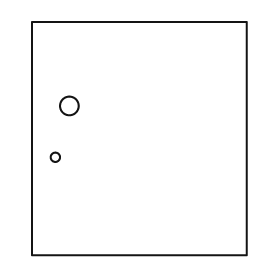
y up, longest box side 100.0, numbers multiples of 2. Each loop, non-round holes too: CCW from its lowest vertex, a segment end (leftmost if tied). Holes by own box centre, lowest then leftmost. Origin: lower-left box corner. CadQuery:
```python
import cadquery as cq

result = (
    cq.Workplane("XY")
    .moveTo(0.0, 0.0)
    .lineTo(92.0, 0.0)
    .lineTo(92.0, 100.0)
    .lineTo(0.0, 100.0)
    .close()
    .moveTo(10.0, 42.0)
    .circle(2.0)
    .moveTo(16.0, 64.0)
    .circle(4.0)
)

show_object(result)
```